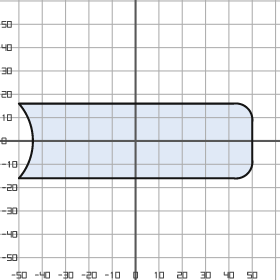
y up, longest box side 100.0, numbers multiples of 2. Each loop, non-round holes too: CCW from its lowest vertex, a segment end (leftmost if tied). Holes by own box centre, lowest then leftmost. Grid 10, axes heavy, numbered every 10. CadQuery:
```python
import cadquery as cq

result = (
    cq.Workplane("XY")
    .moveTo(-50.0, -16.0)
    .lineTo(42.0, -16.0)
    .threePointArc((48.0, -14.0), (50.0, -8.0))
    .lineTo(50.0, 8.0)
    .threePointArc((48.0, 14.0), (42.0, 16.0))
    .lineTo(-50.0, 16.0)
    .threePointArc((-44.0, 0.0), (-50.0, -16.0))
    .close()
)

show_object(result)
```